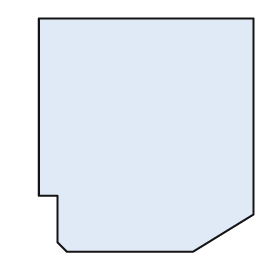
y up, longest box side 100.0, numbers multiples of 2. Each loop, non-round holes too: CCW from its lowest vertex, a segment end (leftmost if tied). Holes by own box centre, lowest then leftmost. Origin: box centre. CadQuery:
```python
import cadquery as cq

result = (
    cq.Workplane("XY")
    .moveTo(-34.0, -50.0)
    .lineTo(20.0, -50.0)
    .lineTo(46.0, -34.0)
    .lineTo(46.0, 50.0)
    .lineTo(-46.0, 50.0)
    .lineTo(-46.0, -26.0)
    .lineTo(-38.0, -26.0)
    .lineTo(-38.0, -46.0)
    .close()
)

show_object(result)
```